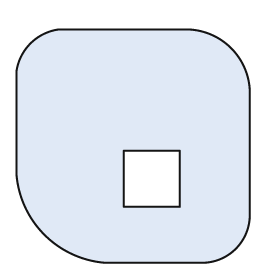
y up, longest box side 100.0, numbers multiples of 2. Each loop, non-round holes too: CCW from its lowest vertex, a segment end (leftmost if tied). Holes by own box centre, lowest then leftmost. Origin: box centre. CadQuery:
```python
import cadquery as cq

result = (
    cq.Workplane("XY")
    .moveTo(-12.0, -50.0)
    .lineTo(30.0, -50.0)
    .threePointArc((44.0, -44.0), (50.0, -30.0))
    .lineTo(50.0, 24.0)
    .threePointArc((42.0, 42.0), (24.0, 50.0))
    .lineTo(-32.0, 50.0)
    .threePointArc((-44.0, 44.0), (-50.0, 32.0))
    .lineTo(-50.0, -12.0)
    .threePointArc((-38.0, -38.0), (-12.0, -50.0))
    .close()
    .moveTo(-4.0, -26.0)
    .lineTo(20.0, -26.0)
    .lineTo(20.0, -2.0)
    .lineTo(-4.0, -2.0)
    .close()
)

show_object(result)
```